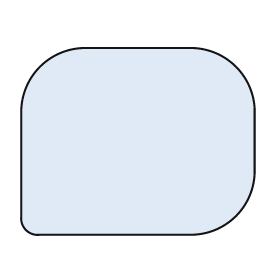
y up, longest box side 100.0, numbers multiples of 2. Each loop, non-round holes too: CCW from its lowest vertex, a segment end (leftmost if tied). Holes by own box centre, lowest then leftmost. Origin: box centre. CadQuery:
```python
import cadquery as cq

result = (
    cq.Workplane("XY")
    .moveTo(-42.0, -40.0)
    .lineTo(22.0, -40.0)
    .threePointArc((42.0, -32.0), (50.0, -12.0))
    .lineTo(50.0, 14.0)
    .threePointArc((42.0, 32.0), (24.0, 40.0))
    .lineTo(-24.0, 40.0)
    .threePointArc((-42.0, 32.0), (-50.0, 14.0))
    .lineTo(-50.0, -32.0)
    .threePointArc((-48.0, -38.0), (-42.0, -40.0))
    .close()
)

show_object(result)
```